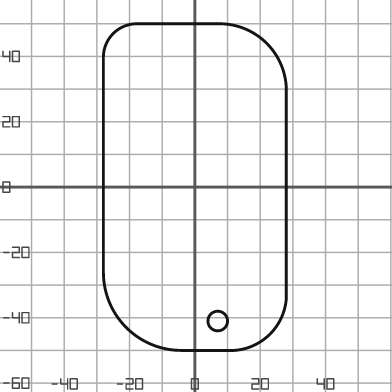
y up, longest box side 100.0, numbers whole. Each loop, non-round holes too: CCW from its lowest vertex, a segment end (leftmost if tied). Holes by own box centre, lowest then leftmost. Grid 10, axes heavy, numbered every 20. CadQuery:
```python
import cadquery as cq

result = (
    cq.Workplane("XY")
    .moveTo(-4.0, -50.0)
    .lineTo(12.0, -50.0)
    .threePointArc((23.0, -45.0), (28.0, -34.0))
    .lineTo(28.0, 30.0)
    .threePointArc((22.0, 44.0), (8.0, 50.0))
    .lineTo(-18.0, 50.0)
    .threePointArc((-25.0, 47.0), (-28.0, 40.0))
    .lineTo(-28.0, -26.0)
    .threePointArc((-21.0, -43.0), (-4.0, -50.0))
    .close()
    .moveTo(7.0, -41.0)
    .circle(3.0)
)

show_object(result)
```